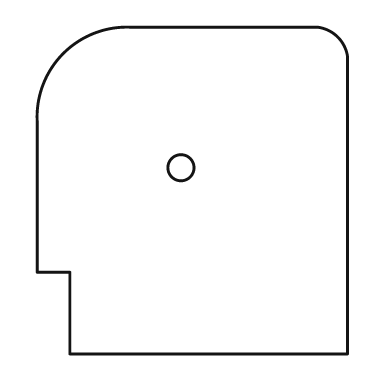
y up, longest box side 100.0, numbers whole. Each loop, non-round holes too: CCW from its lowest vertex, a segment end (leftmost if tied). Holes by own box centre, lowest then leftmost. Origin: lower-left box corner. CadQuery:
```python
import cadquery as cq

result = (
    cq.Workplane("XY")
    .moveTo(10.0, 0.0)
    .lineTo(95.0, 0.0)
    .lineTo(95.0, 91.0)
    .threePointArc((92.0, 97.0), (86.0, 100.0))
    .lineTo(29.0, 100.0)
    .threePointArc((8.0, 92.0), (0.0, 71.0))
    .lineTo(0.0, 25.0)
    .lineTo(10.0, 25.0)
    .close()
    .moveTo(44.0, 57.0)
    .circle(4.0)
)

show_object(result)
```